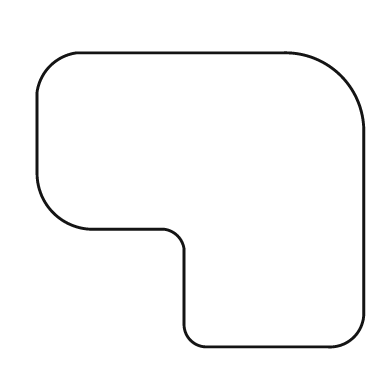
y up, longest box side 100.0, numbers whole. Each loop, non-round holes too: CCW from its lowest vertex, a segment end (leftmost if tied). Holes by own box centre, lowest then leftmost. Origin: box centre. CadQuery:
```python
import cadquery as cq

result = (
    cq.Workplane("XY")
    .moveTo(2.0, -45.0)
    .lineTo(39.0, -45.0)
    .threePointArc((47.0, -42.0), (50.0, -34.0))
    .lineTo(50.0, 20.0)
    .threePointArc((43.0, 38.0), (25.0, 45.0))
    .lineTo(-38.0, 45.0)
    .threePointArc((-46.0, 41.0), (-50.0, 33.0))
    .lineTo(-50.0, 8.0)
    .threePointArc((-45.0, -4.0), (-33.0, -9.0))
    .lineTo(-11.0, -9.0)
    .threePointArc((-7.0, -11.0), (-5.0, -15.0))
    .lineTo(-5.0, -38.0)
    .threePointArc((-3.0, -43.0), (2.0, -45.0))
    .close()
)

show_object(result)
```